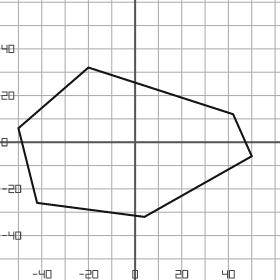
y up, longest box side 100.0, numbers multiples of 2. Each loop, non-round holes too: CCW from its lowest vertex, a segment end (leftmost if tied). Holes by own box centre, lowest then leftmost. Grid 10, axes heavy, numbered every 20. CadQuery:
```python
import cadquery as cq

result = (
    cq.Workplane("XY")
    .moveTo(4.0, -32.0)
    .lineTo(50.0, -6.0)
    .lineTo(42.0, 12.0)
    .lineTo(-20.0, 32.0)
    .lineTo(-50.0, 6.0)
    .lineTo(-42.0, -26.0)
    .close()
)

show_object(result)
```